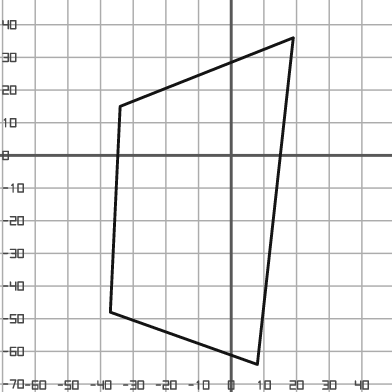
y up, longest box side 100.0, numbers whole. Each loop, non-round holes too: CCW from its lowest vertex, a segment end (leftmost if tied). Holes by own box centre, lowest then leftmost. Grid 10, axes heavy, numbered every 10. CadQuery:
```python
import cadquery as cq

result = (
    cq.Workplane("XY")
    .moveTo(8.0, -64.0)
    .lineTo(19.0, 36.0)
    .lineTo(-34.0, 15.0)
    .lineTo(-37.0, -48.0)
    .close()
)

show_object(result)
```